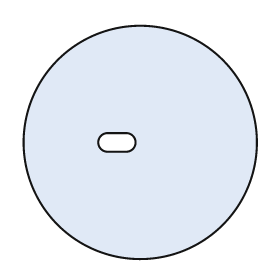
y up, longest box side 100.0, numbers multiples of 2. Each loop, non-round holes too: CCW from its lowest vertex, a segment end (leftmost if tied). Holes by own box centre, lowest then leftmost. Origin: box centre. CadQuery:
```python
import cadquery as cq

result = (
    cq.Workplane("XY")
    .moveTo(0.0, 0.0)
    .circle(50.0)
    .moveTo(-14.0, -4.0)
    .lineTo(-6.0, -4.0)
    .threePointArc((-2.0, 0.0), (-6.0, 4.0))
    .lineTo(-14.0, 4.0)
    .threePointArc((-18.0, 0.0), (-14.0, -4.0))
    .close()
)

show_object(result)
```